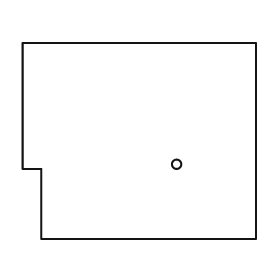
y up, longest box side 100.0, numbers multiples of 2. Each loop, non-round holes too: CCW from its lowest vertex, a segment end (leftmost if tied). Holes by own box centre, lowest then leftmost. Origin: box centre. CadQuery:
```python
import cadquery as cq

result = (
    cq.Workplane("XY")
    .moveTo(-42.0, -42.0)
    .lineTo(50.0, -42.0)
    .lineTo(50.0, 42.0)
    .lineTo(-50.0, 42.0)
    .lineTo(-50.0, -12.0)
    .lineTo(-42.0, -12.0)
    .close()
    .moveTo(16.0, -10.0)
    .circle(2.0)
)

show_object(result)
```